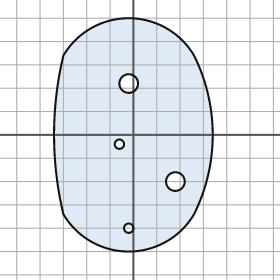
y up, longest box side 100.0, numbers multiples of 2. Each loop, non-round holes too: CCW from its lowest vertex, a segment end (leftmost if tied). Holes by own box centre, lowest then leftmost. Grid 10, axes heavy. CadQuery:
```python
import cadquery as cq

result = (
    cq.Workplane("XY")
    .moveTo(-30.0, -34.0)
    .threePointArc((-2.0, -50.0), (26.0, -34.0))
    .threePointArc((34.0, 0.0), (26.0, 34.0))
    .threePointArc((-2.0, 50.0), (-30.0, 34.0))
    .threePointArc((-34.0, 0.0), (-30.0, -34.0))
    .close()
    .moveTo(-2.0, -40.0)
    .circle(2.0)
    .moveTo(18.0, -20.0)
    .circle(4.0)
    .moveTo(-6.0, -4.0)
    .circle(2.0)
    .moveTo(-2.0, 22.0)
    .circle(4.0)
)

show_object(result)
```